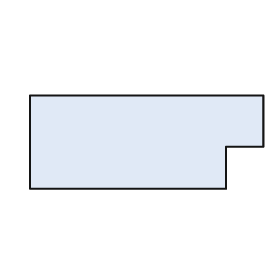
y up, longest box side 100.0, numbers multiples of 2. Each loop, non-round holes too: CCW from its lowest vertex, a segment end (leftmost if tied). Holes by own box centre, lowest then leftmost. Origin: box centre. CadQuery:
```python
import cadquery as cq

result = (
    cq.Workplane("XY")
    .moveTo(-50.0, -20.0)
    .lineTo(34.0, -20.0)
    .lineTo(34.0, -2.0)
    .lineTo(50.0, -2.0)
    .lineTo(50.0, 20.0)
    .lineTo(-50.0, 20.0)
    .close()
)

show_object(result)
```